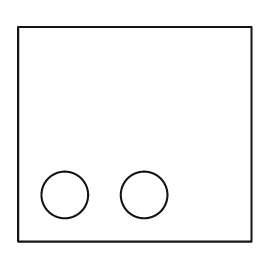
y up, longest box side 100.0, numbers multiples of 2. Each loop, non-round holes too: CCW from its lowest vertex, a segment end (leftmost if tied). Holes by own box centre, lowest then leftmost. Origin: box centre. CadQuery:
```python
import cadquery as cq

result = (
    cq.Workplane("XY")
    .moveTo(-50.0, -46.0)
    .lineTo(50.0, -46.0)
    .lineTo(50.0, 46.0)
    .lineTo(-50.0, 46.0)
    .close()
    .moveTo(-30.0, -26.0)
    .circle(10.0)
    .moveTo(4.0, -26.0)
    .circle(10.0)
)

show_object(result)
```